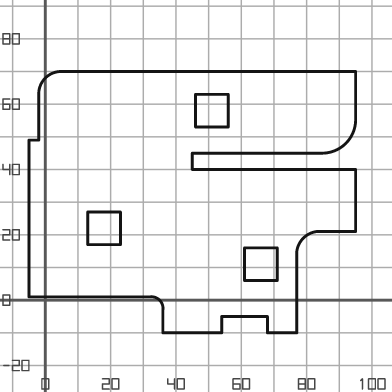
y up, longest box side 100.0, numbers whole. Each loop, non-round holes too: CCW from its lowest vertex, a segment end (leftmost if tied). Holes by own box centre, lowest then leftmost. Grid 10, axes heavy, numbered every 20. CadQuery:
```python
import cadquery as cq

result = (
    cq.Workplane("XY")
    .moveTo(36.0, -10.0)
    .lineTo(54.0, -10.0)
    .lineTo(54.0, -5.0)
    .lineTo(68.0, -5.0)
    .lineTo(68.0, -10.0)
    .lineTo(77.0, -10.0)
    .lineTo(77.0, 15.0)
    .threePointArc((79.0, 19.0), (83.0, 21.0))
    .lineTo(95.0, 21.0)
    .lineTo(95.0, 40.0)
    .lineTo(45.0, 40.0)
    .lineTo(45.0, 45.0)
    .lineTo(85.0, 45.0)
    .threePointArc((92.0, 48.0), (95.0, 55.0))
    .lineTo(95.0, 70.0)
    .lineTo(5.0, 70.0)
    .threePointArc((0.0, 68.0), (-2.0, 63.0))
    .lineTo(-2.0, 49.0)
    .lineTo(-5.0, 49.0)
    .lineTo(-5.0, 1.0)
    .lineTo(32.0, 1.0)
    .threePointArc((35.0, 0.0), (36.0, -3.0))
    .close()
    .moveTo(61.0, 6.0)
    .lineTo(71.0, 6.0)
    .lineTo(71.0, 16.0)
    .lineTo(61.0, 16.0)
    .close()
    .moveTo(13.0, 17.0)
    .lineTo(23.0, 17.0)
    .lineTo(23.0, 27.0)
    .lineTo(13.0, 27.0)
    .close()
    .moveTo(46.0, 53.0)
    .lineTo(56.0, 53.0)
    .lineTo(56.0, 63.0)
    .lineTo(46.0, 63.0)
    .close()
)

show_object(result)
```